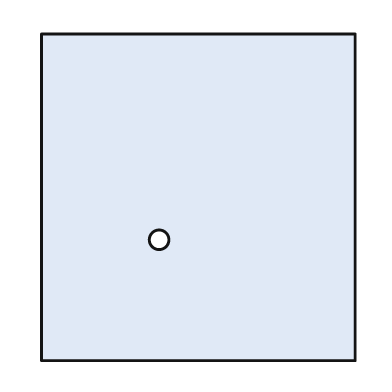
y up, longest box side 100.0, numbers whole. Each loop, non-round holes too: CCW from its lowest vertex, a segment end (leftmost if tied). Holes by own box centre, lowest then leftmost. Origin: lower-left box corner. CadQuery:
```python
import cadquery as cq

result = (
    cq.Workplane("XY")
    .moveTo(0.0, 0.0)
    .lineTo(96.0, 0.0)
    .lineTo(96.0, 100.0)
    .lineTo(0.0, 100.0)
    .close()
    .moveTo(36.0, 37.0)
    .circle(3.0)
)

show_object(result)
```